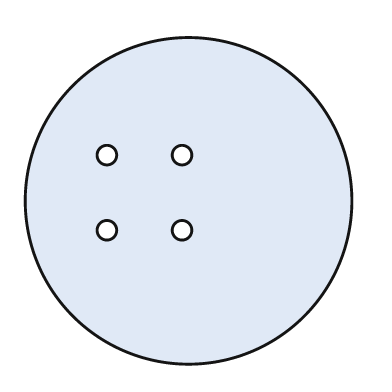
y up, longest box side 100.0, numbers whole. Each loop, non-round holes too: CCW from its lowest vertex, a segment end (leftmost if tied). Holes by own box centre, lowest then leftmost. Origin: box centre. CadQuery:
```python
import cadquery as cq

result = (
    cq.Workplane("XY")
    .moveTo(0.0, 0.0)
    .circle(50.0)
    .moveTo(-25.0, -9.0)
    .circle(3.0)
    .moveTo(-2.0, -9.0)
    .circle(3.0)
    .moveTo(-25.0, 14.0)
    .circle(3.0)
    .moveTo(-2.0, 14.0)
    .circle(3.0)
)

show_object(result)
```